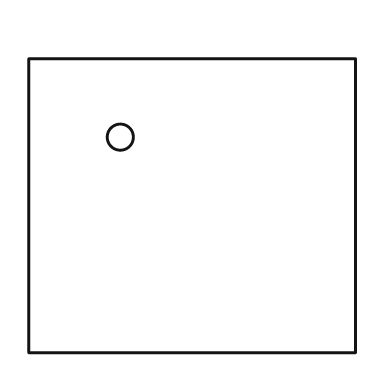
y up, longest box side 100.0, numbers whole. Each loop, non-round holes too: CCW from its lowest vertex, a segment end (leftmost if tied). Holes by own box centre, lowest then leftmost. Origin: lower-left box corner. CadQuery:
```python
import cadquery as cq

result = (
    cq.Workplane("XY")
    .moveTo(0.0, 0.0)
    .lineTo(100.0, 0.0)
    .lineTo(100.0, 90.0)
    .lineTo(0.0, 90.0)
    .close()
    .moveTo(28.0, 66.0)
    .circle(4.0)
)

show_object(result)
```